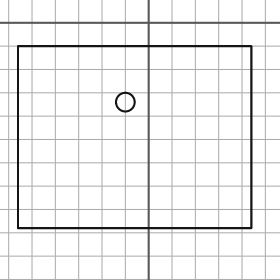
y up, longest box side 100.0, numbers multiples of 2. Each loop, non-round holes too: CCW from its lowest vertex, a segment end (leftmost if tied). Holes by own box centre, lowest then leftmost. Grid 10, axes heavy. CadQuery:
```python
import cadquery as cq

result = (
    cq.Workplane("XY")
    .moveTo(-56.0, -88.0)
    .lineTo(44.0, -88.0)
    .lineTo(44.0, -10.0)
    .lineTo(-56.0, -10.0)
    .close()
    .moveTo(-10.0, -34.0)
    .circle(4.0)
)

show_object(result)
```